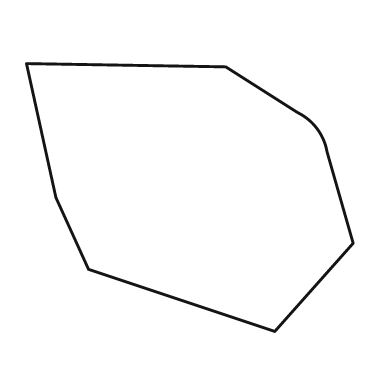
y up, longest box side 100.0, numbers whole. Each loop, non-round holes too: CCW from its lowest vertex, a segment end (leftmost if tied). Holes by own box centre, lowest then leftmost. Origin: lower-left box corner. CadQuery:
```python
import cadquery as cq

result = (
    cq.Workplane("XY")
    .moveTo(76.0, 0.0)
    .lineTo(100.0, 27.0)
    .lineTo(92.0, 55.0)
    .threePointArc((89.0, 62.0), (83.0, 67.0))
    .lineTo(61.0, 81.0)
    .lineTo(0.0, 82.0)
    .lineTo(9.0, 41.0)
    .lineTo(19.0, 19.0)
    .close()
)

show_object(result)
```